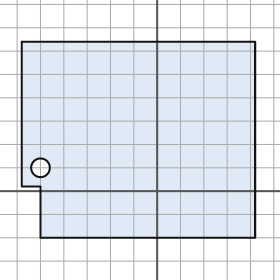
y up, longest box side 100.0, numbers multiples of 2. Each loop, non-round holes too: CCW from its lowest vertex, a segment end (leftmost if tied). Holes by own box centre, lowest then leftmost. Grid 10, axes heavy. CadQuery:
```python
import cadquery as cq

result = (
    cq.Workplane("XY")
    .moveTo(-50.0, -20.0)
    .lineTo(42.0, -20.0)
    .lineTo(42.0, 64.0)
    .lineTo(-58.0, 64.0)
    .lineTo(-58.0, 2.0)
    .lineTo(-50.0, 2.0)
    .close()
    .moveTo(-50.0, 10.0)
    .circle(4.0)
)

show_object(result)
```